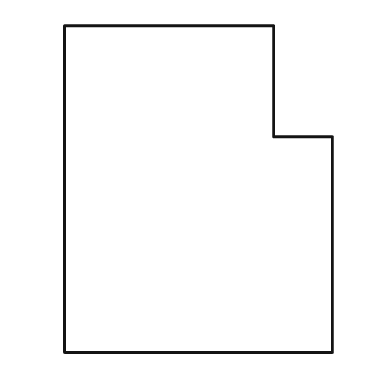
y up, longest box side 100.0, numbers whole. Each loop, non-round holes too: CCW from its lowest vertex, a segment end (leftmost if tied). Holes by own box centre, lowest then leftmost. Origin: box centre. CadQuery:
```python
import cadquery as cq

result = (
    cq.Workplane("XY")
    .moveTo(-41.0, -50.0)
    .lineTo(41.0, -50.0)
    .lineTo(41.0, 16.0)
    .lineTo(23.0, 16.0)
    .lineTo(23.0, 50.0)
    .lineTo(-41.0, 50.0)
    .close()
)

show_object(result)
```